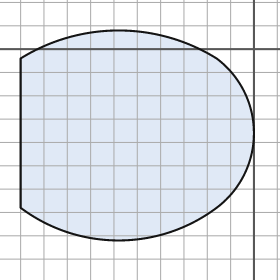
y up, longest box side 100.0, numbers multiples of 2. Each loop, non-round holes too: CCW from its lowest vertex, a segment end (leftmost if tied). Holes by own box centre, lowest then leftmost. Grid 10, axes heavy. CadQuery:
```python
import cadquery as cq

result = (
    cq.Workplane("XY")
    .moveTo(-100.0, -68.0)
    .threePointArc((-58.0, -82.0), (-16.0, -68.0))
    .threePointArc((0.0, -36.0), (-16.0, -4.0))
    .threePointArc((-58.0, 8.0), (-100.0, -4.0))
    .close()
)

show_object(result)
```